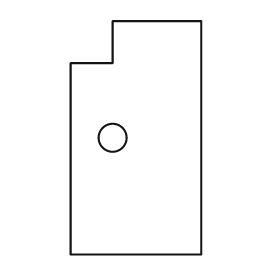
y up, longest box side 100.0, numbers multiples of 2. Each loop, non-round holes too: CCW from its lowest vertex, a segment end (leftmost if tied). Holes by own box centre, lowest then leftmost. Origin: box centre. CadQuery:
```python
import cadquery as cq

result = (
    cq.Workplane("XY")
    .moveTo(-28.0, -50.0)
    .lineTo(28.0, -50.0)
    .lineTo(28.0, 50.0)
    .lineTo(-10.0, 50.0)
    .lineTo(-10.0, 32.0)
    .lineTo(-28.0, 32.0)
    .close()
    .moveTo(-10.0, 0.0)
    .circle(6.0)
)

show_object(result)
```